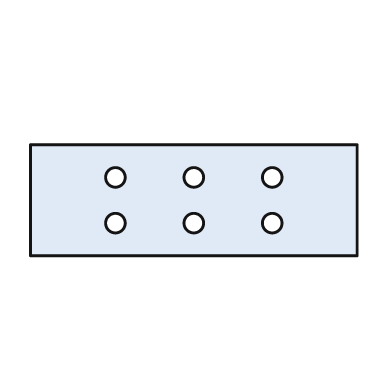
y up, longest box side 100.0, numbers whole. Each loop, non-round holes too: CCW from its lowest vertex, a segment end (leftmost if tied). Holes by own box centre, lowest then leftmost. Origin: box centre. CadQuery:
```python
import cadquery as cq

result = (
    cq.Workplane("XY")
    .moveTo(-50.0, -17.0)
    .lineTo(50.0, -17.0)
    .lineTo(50.0, 17.0)
    .lineTo(-50.0, 17.0)
    .close()
    .moveTo(-24.0, -7.0)
    .circle(3.0)
    .moveTo(0.0, -7.0)
    .circle(3.0)
    .moveTo(24.0, -7.0)
    .circle(3.0)
    .moveTo(-24.0, 7.0)
    .circle(3.0)
    .moveTo(0.0, 7.0)
    .circle(3.0)
    .moveTo(24.0, 7.0)
    .circle(3.0)
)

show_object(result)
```